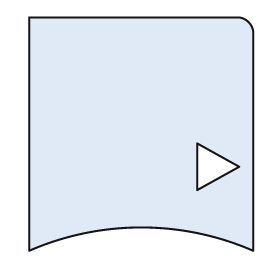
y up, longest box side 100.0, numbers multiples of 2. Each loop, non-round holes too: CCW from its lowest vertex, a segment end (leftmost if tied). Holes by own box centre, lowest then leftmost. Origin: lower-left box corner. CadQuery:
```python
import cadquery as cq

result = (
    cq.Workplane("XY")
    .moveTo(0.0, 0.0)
    .threePointArc((48.0, 10.0), (96.0, 0.0))
    .lineTo(96.0, 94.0)
    .threePointArc((94.0, 98.0), (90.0, 100.0))
    .lineTo(0.0, 100.0)
    .close()
    .moveTo(72.0, 26.0)
    .lineTo(90.0, 36.0)
    .lineTo(72.0, 46.0)
    .close()
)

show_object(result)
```